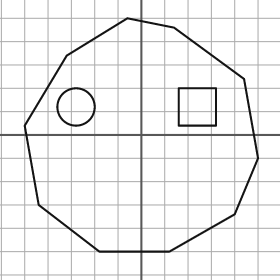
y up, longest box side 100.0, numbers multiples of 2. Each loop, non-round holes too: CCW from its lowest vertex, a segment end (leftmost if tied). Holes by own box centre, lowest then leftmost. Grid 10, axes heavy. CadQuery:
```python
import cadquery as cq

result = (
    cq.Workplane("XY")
    .moveTo(-18.0, -50.0)
    .lineTo(12.0, -50.0)
    .lineTo(40.0, -34.0)
    .lineTo(50.0, -10.0)
    .lineTo(44.0, 24.0)
    .lineTo(14.0, 46.0)
    .lineTo(-6.0, 50.0)
    .lineTo(-32.0, 34.0)
    .lineTo(-50.0, 4.0)
    .lineTo(-44.0, -30.0)
    .close()
    .moveTo(-28.0, 12.0)
    .circle(8.0)
    .moveTo(16.0, 4.0)
    .lineTo(32.0, 4.0)
    .lineTo(32.0, 20.0)
    .lineTo(16.0, 20.0)
    .close()
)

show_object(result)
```